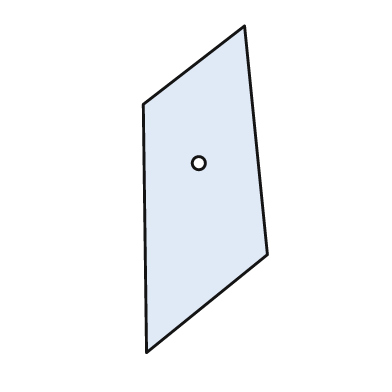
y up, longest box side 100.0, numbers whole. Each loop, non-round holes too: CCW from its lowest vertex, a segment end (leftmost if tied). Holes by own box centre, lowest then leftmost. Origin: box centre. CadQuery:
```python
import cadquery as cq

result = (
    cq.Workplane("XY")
    .moveTo(-18.0, -50.0)
    .lineTo(19.0, -20.0)
    .lineTo(12.0, 50.0)
    .lineTo(-19.0, 26.0)
    .close()
    .moveTo(-2.0, 8.0)
    .circle(2.0)
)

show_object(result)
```